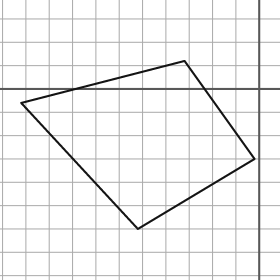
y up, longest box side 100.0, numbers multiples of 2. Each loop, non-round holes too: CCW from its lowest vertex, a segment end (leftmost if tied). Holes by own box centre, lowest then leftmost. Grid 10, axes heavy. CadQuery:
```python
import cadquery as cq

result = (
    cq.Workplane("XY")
    .moveTo(-52.0, -60.0)
    .lineTo(-2.0, -30.0)
    .lineTo(-32.0, 12.0)
    .lineTo(-102.0, -6.0)
    .close()
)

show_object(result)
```